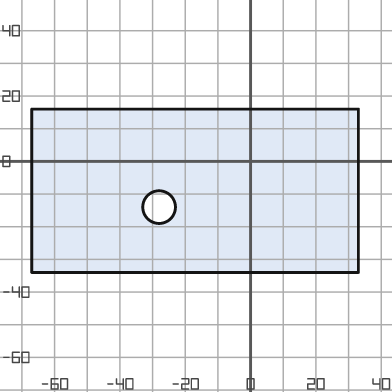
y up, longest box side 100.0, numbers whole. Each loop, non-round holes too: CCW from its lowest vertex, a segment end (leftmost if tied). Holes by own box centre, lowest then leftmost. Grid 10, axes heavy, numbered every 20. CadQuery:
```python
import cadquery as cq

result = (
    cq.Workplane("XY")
    .moveTo(-67.0, -34.0)
    .lineTo(33.0, -34.0)
    .lineTo(33.0, 16.0)
    .lineTo(-67.0, 16.0)
    .close()
    .moveTo(-28.0, -14.0)
    .circle(5.0)
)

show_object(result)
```